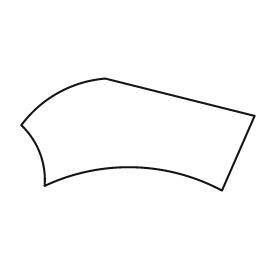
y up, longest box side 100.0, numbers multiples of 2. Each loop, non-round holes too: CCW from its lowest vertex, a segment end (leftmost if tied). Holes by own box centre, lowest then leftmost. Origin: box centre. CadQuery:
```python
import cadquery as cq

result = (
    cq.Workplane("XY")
    .moveTo(36.0, -24.0)
    .lineTo(50.0, 8.0)
    .lineTo(-14.0, 24.0)
    .threePointArc((-34.0, 18.0), (-50.0, 4.0))
    .threePointArc((-42.0, -8.0), (-40.0, -22.0))
    .threePointArc((-2.0, -14.0), (36.0, -24.0))
    .close()
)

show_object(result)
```